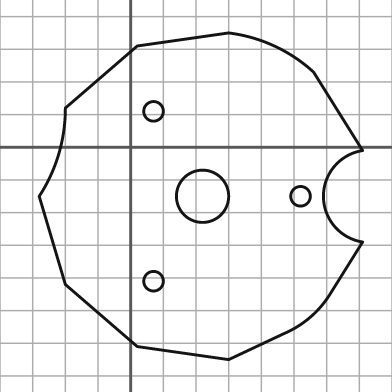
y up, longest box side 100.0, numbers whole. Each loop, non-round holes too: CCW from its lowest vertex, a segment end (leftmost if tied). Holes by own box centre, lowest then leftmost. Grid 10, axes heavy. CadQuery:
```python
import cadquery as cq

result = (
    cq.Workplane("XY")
    .moveTo(30.0, -65.0)
    .lineTo(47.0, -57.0)
    .threePointArc((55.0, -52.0), (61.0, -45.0))
    .lineTo(71.0, -29.0)
    .threePointArc((59.0, -15.0), (71.0, -1.0))
    .lineTo(56.0, 23.0)
    .threePointArc((44.0, 31.0), (30.0, 35.0))
    .lineTo(2.0, 31.0)
    .lineTo(-20.0, 12.0)
    .threePointArc((-22.0, -2.0), (-28.0, -15.0))
    .lineTo(-20.0, -42.0)
    .lineTo(2.0, -61.0)
    .close()
    .moveTo(7.0, -41.0)
    .circle(3.0)
    .moveTo(22.0, -15.0)
    .circle(8.0)
    .moveTo(52.0, -15.0)
    .circle(3.0)
    .moveTo(7.0, 11.0)
    .circle(3.0)
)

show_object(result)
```